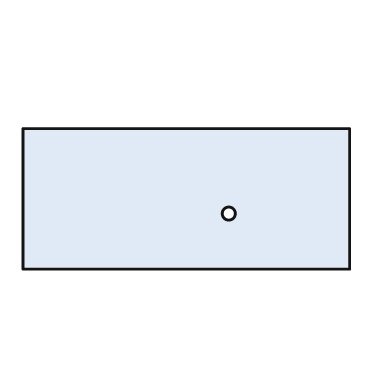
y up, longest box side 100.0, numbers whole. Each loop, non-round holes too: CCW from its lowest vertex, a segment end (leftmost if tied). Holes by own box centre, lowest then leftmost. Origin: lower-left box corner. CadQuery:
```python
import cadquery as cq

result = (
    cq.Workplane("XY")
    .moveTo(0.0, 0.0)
    .lineTo(100.0, 0.0)
    .lineTo(100.0, 43.0)
    .lineTo(0.0, 43.0)
    .close()
    .moveTo(63.0, 17.0)
    .circle(2.0)
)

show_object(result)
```